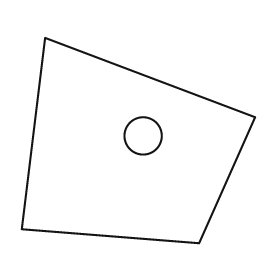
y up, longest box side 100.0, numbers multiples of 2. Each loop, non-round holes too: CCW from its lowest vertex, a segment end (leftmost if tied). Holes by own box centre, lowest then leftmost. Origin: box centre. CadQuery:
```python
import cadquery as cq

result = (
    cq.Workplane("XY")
    .moveTo(26.0, -44.0)
    .lineTo(50.0, 10.0)
    .lineTo(-40.0, 44.0)
    .lineTo(-50.0, -38.0)
    .close()
    .moveTo(2.0, 2.0)
    .circle(8.0)
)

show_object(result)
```